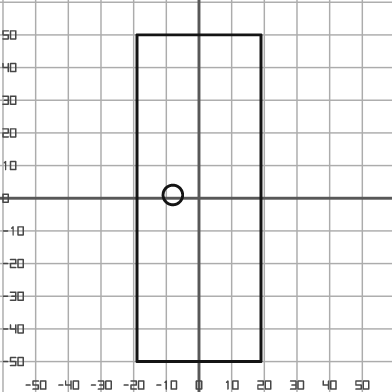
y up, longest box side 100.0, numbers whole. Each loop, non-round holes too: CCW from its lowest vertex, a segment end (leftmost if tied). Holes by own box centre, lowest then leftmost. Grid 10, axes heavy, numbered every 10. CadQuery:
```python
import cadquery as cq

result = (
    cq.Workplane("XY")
    .moveTo(-19.0, -50.0)
    .lineTo(19.0, -50.0)
    .lineTo(19.0, 50.0)
    .lineTo(-19.0, 50.0)
    .close()
    .moveTo(-8.0, 1.0)
    .circle(3.0)
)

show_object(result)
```